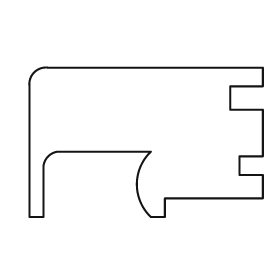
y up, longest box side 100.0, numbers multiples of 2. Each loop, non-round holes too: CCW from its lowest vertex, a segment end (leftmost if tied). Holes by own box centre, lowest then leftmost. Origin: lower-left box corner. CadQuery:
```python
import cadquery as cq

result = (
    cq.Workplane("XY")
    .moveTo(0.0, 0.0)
    .lineTo(6.0, 0.0)
    .lineTo(6.0, 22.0)
    .threePointArc((8.0, 26.0), (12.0, 28.0))
    .lineTo(52.0, 28.0)
    .threePointArc((46.0, 14.0), (52.0, 0.0))
    .lineTo(58.0, 0.0)
    .lineTo(58.0, 8.0)
    .lineTo(100.0, 8.0)
    .lineTo(100.0, 18.0)
    .lineTo(90.0, 18.0)
    .lineTo(90.0, 26.0)
    .lineTo(100.0, 26.0)
    .lineTo(100.0, 46.0)
    .lineTo(86.0, 46.0)
    .lineTo(86.0, 56.0)
    .lineTo(100.0, 56.0)
    .lineTo(100.0, 64.0)
    .lineTo(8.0, 64.0)
    .threePointArc((2.0, 62.0), (0.0, 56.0))
    .close()
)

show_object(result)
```